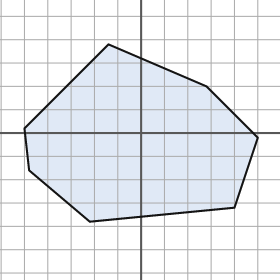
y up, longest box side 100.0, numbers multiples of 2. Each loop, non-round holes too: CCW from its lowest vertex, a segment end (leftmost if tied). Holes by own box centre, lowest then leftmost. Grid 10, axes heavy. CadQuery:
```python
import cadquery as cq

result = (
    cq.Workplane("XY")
    .moveTo(-22.0, -38.0)
    .lineTo(40.0, -32.0)
    .lineTo(50.0, -2.0)
    .lineTo(28.0, 20.0)
    .lineTo(-14.0, 38.0)
    .lineTo(-50.0, 2.0)
    .lineTo(-48.0, -16.0)
    .close()
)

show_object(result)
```